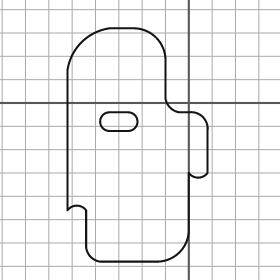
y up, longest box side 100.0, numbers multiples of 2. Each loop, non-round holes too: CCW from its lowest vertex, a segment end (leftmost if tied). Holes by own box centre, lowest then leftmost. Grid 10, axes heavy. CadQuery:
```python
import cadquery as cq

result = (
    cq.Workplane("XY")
    .moveTo(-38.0, -68.0)
    .lineTo(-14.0, -68.0)
    .threePointArc((-4.0, -64.0), (0.0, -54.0))
    .lineTo(0.0, -30.0)
    .threePointArc((4.0, -32.0), (8.0, -30.0))
    .lineTo(8.0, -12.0)
    .threePointArc((6.0, -6.0), (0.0, -4.0))
    .lineTo(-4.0, -4.0)
    .threePointArc((-8.0, -2.0), (-10.0, 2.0))
    .lineTo(-10.0, 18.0)
    .threePointArc((-14.0, 28.0), (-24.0, 32.0))
    .lineTo(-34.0, 32.0)
    .threePointArc((-46.0, 26.0), (-52.0, 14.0))
    .lineTo(-52.0, -46.0)
    .threePointArc((-48.0, -44.0), (-44.0, -46.0))
    .lineTo(-44.0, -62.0)
    .threePointArc((-42.0, -66.0), (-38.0, -68.0))
    .close()
    .moveTo(-34.0, -12.0)
    .lineTo(-26.0, -12.0)
    .threePointArc((-22.0, -8.0), (-26.0, -4.0))
    .lineTo(-34.0, -4.0)
    .threePointArc((-38.0, -8.0), (-34.0, -12.0))
    .close()
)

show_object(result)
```